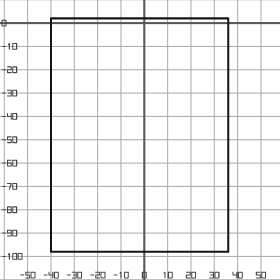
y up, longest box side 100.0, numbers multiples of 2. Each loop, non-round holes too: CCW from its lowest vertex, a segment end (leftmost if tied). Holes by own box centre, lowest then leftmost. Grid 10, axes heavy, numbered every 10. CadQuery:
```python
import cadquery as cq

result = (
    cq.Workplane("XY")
    .moveTo(-40.0, -98.0)
    .lineTo(36.0, -98.0)
    .lineTo(36.0, 2.0)
    .lineTo(-40.0, 2.0)
    .close()
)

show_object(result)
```